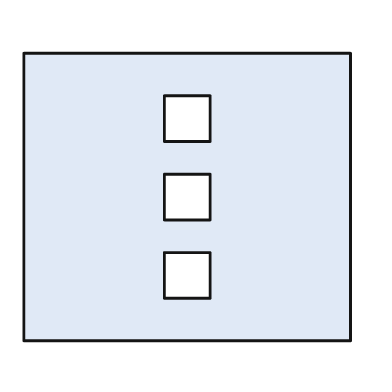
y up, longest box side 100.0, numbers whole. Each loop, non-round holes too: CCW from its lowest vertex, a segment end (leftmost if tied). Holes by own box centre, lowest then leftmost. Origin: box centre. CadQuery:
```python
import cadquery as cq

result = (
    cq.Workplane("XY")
    .moveTo(-50.0, -44.0)
    .lineTo(50.0, -44.0)
    .lineTo(50.0, 44.0)
    .lineTo(-50.0, 44.0)
    .close()
    .moveTo(-7.0, -31.0)
    .lineTo(7.0, -31.0)
    .lineTo(7.0, -17.0)
    .lineTo(-7.0, -17.0)
    .close()
    .moveTo(-7.0, -7.0)
    .lineTo(7.0, -7.0)
    .lineTo(7.0, 7.0)
    .lineTo(-7.0, 7.0)
    .close()
    .moveTo(-7.0, 17.0)
    .lineTo(7.0, 17.0)
    .lineTo(7.0, 31.0)
    .lineTo(-7.0, 31.0)
    .close()
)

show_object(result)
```